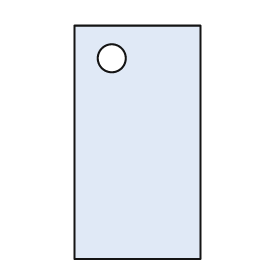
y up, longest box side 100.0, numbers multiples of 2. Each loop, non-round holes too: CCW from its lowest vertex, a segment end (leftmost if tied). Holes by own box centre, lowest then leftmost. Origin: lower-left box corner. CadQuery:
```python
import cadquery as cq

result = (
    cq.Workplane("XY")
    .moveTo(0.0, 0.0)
    .lineTo(54.0, 0.0)
    .lineTo(54.0, 100.0)
    .lineTo(0.0, 100.0)
    .close()
    .moveTo(16.0, 86.0)
    .circle(6.0)
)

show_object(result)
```